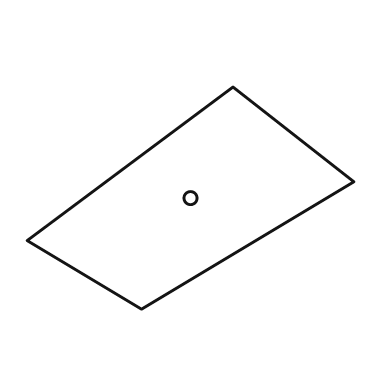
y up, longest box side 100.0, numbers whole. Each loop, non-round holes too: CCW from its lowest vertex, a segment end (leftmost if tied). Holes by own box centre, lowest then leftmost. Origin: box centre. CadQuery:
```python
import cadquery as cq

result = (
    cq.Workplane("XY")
    .moveTo(-15.0, -34.0)
    .lineTo(50.0, 5.0)
    .lineTo(13.0, 34.0)
    .lineTo(-50.0, -13.0)
    .close()
    .moveTo(0.0, 0.0)
    .circle(2.0)
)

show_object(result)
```